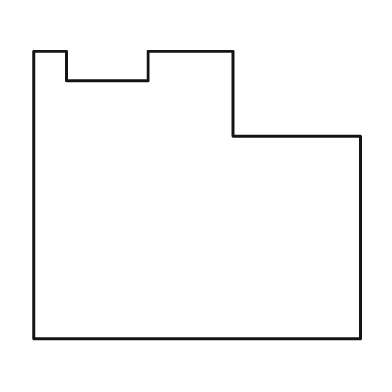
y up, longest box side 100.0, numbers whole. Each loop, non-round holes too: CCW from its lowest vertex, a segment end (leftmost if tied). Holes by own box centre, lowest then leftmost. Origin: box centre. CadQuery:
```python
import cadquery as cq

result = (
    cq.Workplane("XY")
    .moveTo(-50.0, -44.0)
    .lineTo(50.0, -44.0)
    .lineTo(50.0, 18.0)
    .lineTo(11.0, 18.0)
    .lineTo(11.0, 44.0)
    .lineTo(-15.0, 44.0)
    .lineTo(-15.0, 35.0)
    .lineTo(-40.0, 35.0)
    .lineTo(-40.0, 44.0)
    .lineTo(-50.0, 44.0)
    .close()
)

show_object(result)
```